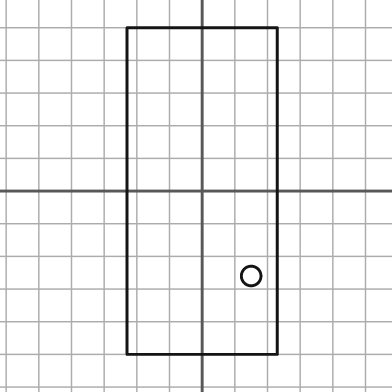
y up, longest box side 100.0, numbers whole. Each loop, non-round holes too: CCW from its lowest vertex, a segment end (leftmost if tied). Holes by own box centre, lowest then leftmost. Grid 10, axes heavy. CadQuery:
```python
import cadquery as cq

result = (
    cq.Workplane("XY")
    .moveTo(-23.0, -50.0)
    .lineTo(23.0, -50.0)
    .lineTo(23.0, 50.0)
    .lineTo(-23.0, 50.0)
    .close()
    .moveTo(15.0, -26.0)
    .circle(3.0)
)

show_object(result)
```